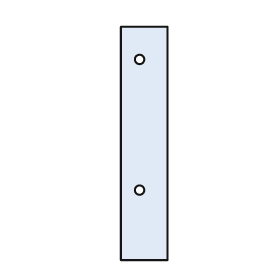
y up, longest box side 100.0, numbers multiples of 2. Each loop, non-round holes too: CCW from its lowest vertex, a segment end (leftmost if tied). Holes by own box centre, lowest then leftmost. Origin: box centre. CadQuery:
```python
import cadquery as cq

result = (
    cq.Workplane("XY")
    .moveTo(-10.0, -50.0)
    .lineTo(10.0, -50.0)
    .lineTo(10.0, 50.0)
    .lineTo(-10.0, 50.0)
    .close()
    .moveTo(-2.0, -20.0)
    .circle(2.0)
    .moveTo(-2.0, 36.0)
    .circle(2.0)
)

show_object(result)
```